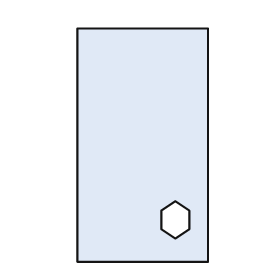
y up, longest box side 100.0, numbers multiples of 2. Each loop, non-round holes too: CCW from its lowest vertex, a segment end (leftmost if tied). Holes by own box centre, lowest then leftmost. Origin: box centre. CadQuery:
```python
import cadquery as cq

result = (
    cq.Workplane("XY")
    .moveTo(-28.0, -50.0)
    .lineTo(28.0, -50.0)
    .lineTo(28.0, 50.0)
    .lineTo(-28.0, 50.0)
    .close()
    .moveTo(14.0, -40.0)
    .lineTo(20.0, -36.0)
    .lineTo(20.0, -28.0)
    .lineTo(14.0, -24.0)
    .lineTo(8.0, -28.0)
    .lineTo(8.0, -36.0)
    .close()
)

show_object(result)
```